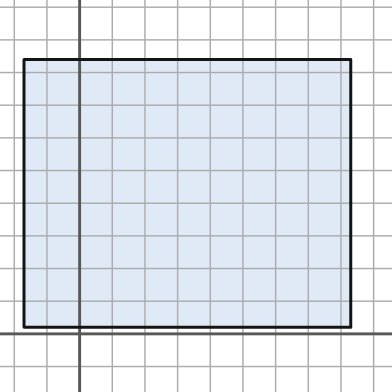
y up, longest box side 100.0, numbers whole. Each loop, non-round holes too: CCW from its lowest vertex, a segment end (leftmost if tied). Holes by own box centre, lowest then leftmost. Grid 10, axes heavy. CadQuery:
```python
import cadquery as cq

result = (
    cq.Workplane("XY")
    .moveTo(-17.0, 2.0)
    .lineTo(83.0, 2.0)
    .lineTo(83.0, 84.0)
    .lineTo(-17.0, 84.0)
    .close()
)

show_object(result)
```